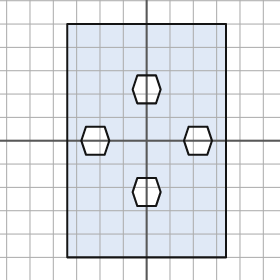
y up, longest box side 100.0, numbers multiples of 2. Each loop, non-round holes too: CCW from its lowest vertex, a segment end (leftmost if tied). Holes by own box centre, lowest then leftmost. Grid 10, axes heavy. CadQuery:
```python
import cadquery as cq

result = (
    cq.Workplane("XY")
    .moveTo(-34.0, -50.0)
    .lineTo(34.0, -50.0)
    .lineTo(34.0, 50.0)
    .lineTo(-34.0, 50.0)
    .close()
    .moveTo(-4.0, -28.0)
    .lineTo(4.0, -28.0)
    .lineTo(6.0, -22.0)
    .lineTo(4.0, -16.0)
    .lineTo(-4.0, -16.0)
    .lineTo(-6.0, -22.0)
    .close()
    .moveTo(-26.0, -6.0)
    .lineTo(-18.0, -6.0)
    .lineTo(-16.0, 0.0)
    .lineTo(-18.0, 6.0)
    .lineTo(-26.0, 6.0)
    .lineTo(-28.0, 0.0)
    .close()
    .moveTo(18.0, -6.0)
    .lineTo(26.0, -6.0)
    .lineTo(28.0, 0.0)
    .lineTo(26.0, 6.0)
    .lineTo(18.0, 6.0)
    .lineTo(16.0, 0.0)
    .close()
    .moveTo(-4.0, 16.0)
    .lineTo(4.0, 16.0)
    .lineTo(6.0, 22.0)
    .lineTo(4.0, 28.0)
    .lineTo(-4.0, 28.0)
    .lineTo(-6.0, 22.0)
    .close()
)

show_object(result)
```